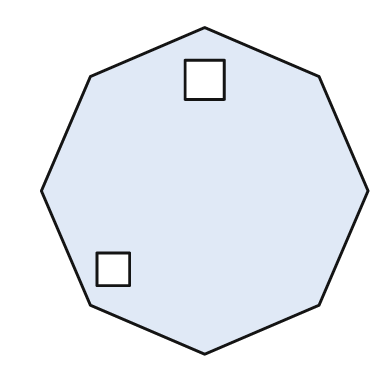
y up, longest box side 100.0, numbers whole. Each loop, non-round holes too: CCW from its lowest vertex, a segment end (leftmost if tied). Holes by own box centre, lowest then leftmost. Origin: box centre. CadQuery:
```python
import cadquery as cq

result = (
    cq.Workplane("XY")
    .moveTo(0.0, -50.0)
    .lineTo(35.0, -35.0)
    .lineTo(50.0, 0.0)
    .lineTo(35.0, 35.0)
    .lineTo(0.0, 50.0)
    .lineTo(-35.0, 35.0)
    .lineTo(-50.0, 0.0)
    .lineTo(-35.0, -35.0)
    .close()
    .moveTo(-33.0, -29.0)
    .lineTo(-23.0, -29.0)
    .lineTo(-23.0, -19.0)
    .lineTo(-33.0, -19.0)
    .close()
    .moveTo(-6.0, 28.0)
    .lineTo(6.0, 28.0)
    .lineTo(6.0, 40.0)
    .lineTo(-6.0, 40.0)
    .close()
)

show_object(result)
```